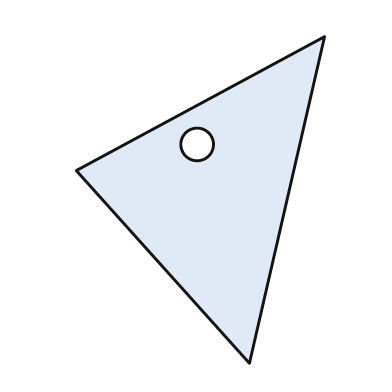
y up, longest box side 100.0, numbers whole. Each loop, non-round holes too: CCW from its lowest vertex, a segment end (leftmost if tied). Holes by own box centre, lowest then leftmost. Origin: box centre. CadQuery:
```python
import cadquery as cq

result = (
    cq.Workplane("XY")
    .moveTo(15.0, -50.0)
    .lineTo(38.0, 50.0)
    .lineTo(-38.0, 9.0)
    .close()
    .moveTo(-1.0, 17.0)
    .circle(5.0)
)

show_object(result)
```